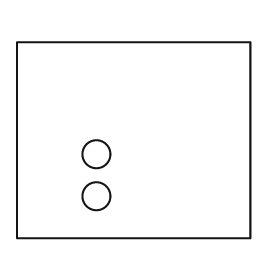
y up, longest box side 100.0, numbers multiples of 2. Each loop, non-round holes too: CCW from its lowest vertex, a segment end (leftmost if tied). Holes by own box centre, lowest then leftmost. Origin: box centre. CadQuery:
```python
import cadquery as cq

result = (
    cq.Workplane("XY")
    .moveTo(-50.0, -42.0)
    .lineTo(50.0, -42.0)
    .lineTo(50.0, 42.0)
    .lineTo(-50.0, 42.0)
    .close()
    .moveTo(-16.0, -24.0)
    .circle(6.0)
    .moveTo(-16.0, -6.0)
    .circle(6.0)
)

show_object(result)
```